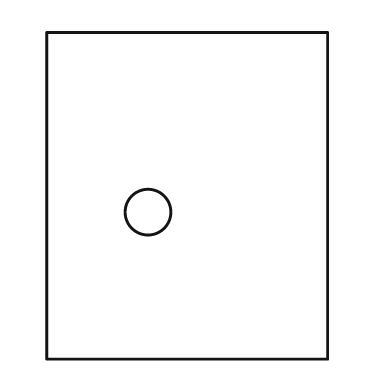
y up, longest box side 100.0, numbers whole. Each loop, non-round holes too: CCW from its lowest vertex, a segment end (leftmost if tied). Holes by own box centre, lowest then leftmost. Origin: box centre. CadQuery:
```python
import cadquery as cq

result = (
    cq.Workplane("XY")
    .moveTo(-43.0, -50.0)
    .lineTo(43.0, -50.0)
    .lineTo(43.0, 50.0)
    .lineTo(-43.0, 50.0)
    .close()
    .moveTo(-12.0, -5.0)
    .circle(7.0)
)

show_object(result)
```